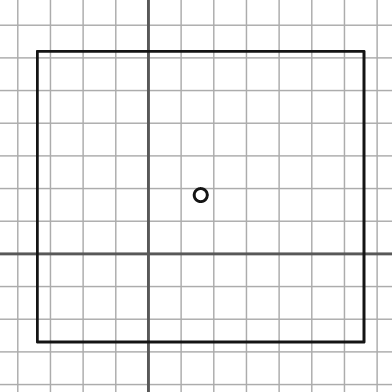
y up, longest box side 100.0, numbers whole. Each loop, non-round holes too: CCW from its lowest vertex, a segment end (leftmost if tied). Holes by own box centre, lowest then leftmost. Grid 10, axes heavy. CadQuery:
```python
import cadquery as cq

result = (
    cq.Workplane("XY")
    .moveTo(-34.0, -27.0)
    .lineTo(66.0, -27.0)
    .lineTo(66.0, 62.0)
    .lineTo(-34.0, 62.0)
    .close()
    .moveTo(16.0, 18.0)
    .circle(2.0)
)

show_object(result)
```